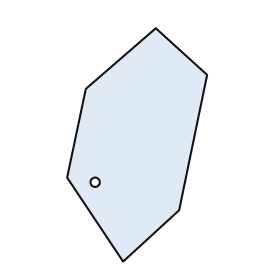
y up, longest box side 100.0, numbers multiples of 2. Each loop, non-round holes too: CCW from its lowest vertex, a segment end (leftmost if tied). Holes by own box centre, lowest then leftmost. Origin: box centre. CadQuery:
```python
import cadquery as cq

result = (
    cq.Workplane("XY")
    .moveTo(-6.0, -50.0)
    .lineTo(18.0, -28.0)
    .lineTo(30.0, 30.0)
    .lineTo(8.0, 50.0)
    .lineTo(-22.0, 24.0)
    .lineTo(-30.0, -14.0)
    .close()
    .moveTo(-18.0, -16.0)
    .circle(2.0)
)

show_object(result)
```